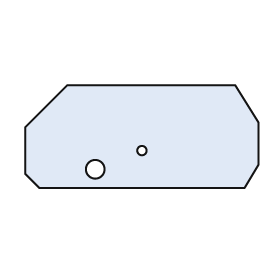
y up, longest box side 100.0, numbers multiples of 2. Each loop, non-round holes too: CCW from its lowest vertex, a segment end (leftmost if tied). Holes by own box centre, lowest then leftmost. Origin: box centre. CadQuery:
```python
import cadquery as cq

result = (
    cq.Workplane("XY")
    .moveTo(-44.0, -22.0)
    .lineTo(44.0, -22.0)
    .lineTo(50.0, -12.0)
    .lineTo(50.0, 6.0)
    .lineTo(40.0, 22.0)
    .lineTo(-32.0, 22.0)
    .lineTo(-50.0, 4.0)
    .lineTo(-50.0, -16.0)
    .close()
    .moveTo(-20.0, -14.0)
    .circle(4.0)
    .moveTo(0.0, -6.0)
    .circle(2.0)
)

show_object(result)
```